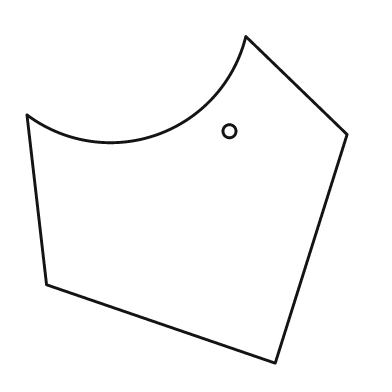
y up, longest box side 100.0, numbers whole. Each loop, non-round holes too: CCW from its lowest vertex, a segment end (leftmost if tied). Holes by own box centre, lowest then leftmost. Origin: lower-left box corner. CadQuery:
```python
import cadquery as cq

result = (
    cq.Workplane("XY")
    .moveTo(76.0, 0.0)
    .lineTo(98.0, 70.0)
    .lineTo(67.0, 100.0)
    .threePointArc((40.0, 70.0), (0.0, 76.0))
    .lineTo(6.0, 24.0)
    .close()
    .moveTo(62.0, 71.0)
    .circle(2.0)
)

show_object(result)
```